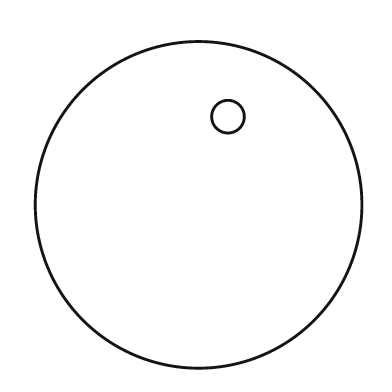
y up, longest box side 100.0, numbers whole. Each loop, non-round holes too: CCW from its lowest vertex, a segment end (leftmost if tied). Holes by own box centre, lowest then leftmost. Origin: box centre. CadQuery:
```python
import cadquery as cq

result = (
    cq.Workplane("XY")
    .moveTo(0.0, 0.0)
    .circle(50.0)
    .moveTo(9.0, 27.0)
    .circle(5.0)
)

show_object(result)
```